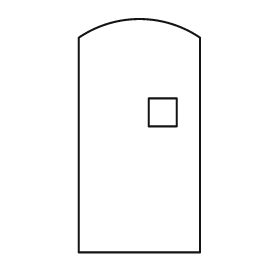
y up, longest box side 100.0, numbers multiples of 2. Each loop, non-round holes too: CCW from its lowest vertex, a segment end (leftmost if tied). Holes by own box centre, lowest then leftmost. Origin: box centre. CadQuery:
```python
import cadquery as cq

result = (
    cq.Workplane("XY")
    .moveTo(-26.0, -50.0)
    .lineTo(26.0, -50.0)
    .lineTo(26.0, 42.0)
    .threePointArc((0.0, 50.0), (-26.0, 42.0))
    .close()
    .moveTo(4.0, 4.0)
    .lineTo(16.0, 4.0)
    .lineTo(16.0, 16.0)
    .lineTo(4.0, 16.0)
    .close()
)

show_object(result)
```